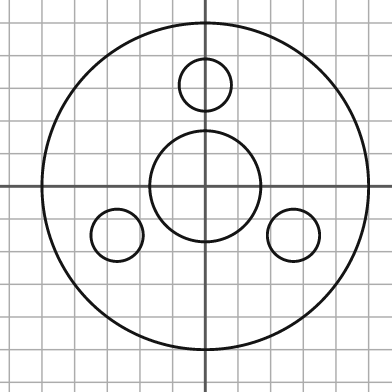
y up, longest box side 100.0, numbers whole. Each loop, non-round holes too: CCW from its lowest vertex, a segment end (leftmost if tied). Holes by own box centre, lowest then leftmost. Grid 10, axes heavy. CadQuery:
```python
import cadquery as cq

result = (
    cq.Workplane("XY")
    .moveTo(0.0, 0.0)
    .circle(50.0)
    .moveTo(-27.0, -15.0)
    .circle(8.0)
    .moveTo(27.0, -15.0)
    .circle(8.0)
    .moveTo(0.0, 0.0)
    .circle(17.0)
    .moveTo(0.0, 31.0)
    .circle(8.0)
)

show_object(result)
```